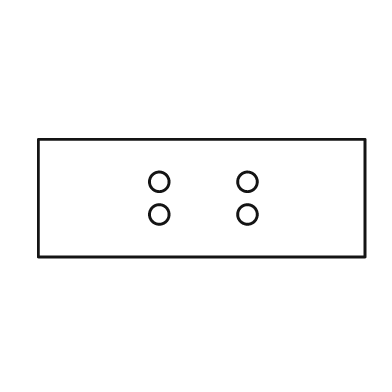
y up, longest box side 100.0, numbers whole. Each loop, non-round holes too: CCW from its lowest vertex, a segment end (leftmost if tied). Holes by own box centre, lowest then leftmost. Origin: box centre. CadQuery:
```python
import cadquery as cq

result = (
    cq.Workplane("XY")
    .moveTo(-50.0, -18.0)
    .lineTo(50.0, -18.0)
    .lineTo(50.0, 18.0)
    .lineTo(-50.0, 18.0)
    .close()
    .moveTo(-13.0, -5.0)
    .circle(3.0)
    .moveTo(14.0, -5.0)
    .circle(3.0)
    .moveTo(-13.0, 5.0)
    .circle(3.0)
    .moveTo(14.0, 5.0)
    .circle(3.0)
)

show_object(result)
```